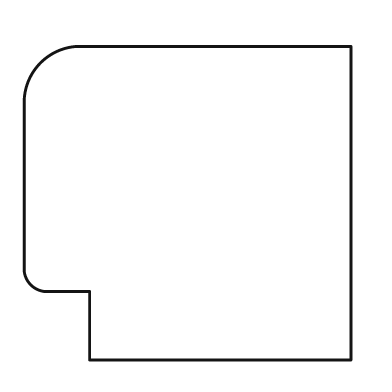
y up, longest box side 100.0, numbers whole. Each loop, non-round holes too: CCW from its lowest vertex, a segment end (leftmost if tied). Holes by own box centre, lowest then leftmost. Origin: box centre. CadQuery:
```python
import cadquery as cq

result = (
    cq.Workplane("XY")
    .moveTo(-30.0, -48.0)
    .lineTo(50.0, -48.0)
    .lineTo(50.0, 48.0)
    .lineTo(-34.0, 48.0)
    .threePointArc((-45.0, 43.0), (-50.0, 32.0))
    .lineTo(-50.0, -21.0)
    .threePointArc((-48.0, -25.0), (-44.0, -27.0))
    .lineTo(-30.0, -27.0)
    .close()
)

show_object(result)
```